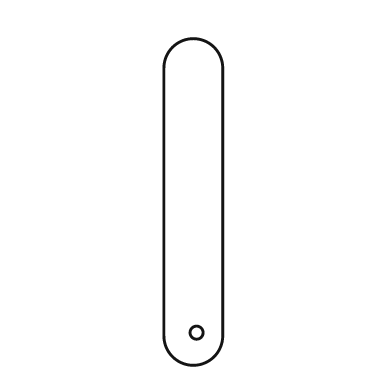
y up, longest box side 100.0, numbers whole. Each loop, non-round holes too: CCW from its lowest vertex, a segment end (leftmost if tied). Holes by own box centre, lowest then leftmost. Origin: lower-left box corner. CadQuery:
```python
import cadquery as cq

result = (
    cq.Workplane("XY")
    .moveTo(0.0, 9.0)
    .threePointArc((9.0, 0.0), (18.0, 9.0))
    .lineTo(18.0, 91.0)
    .threePointArc((9.0, 100.0), (0.0, 91.0))
    .close()
    .moveTo(10.0, 10.0)
    .circle(2.0)
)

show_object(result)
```